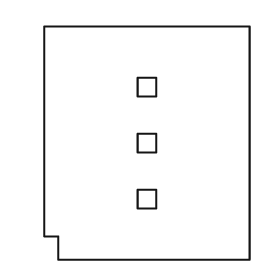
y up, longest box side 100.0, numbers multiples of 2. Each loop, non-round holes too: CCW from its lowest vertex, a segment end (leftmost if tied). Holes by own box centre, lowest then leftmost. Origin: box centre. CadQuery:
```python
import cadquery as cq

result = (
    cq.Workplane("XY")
    .moveTo(-38.0, -50.0)
    .lineTo(44.0, -50.0)
    .lineTo(44.0, 50.0)
    .lineTo(-44.0, 50.0)
    .lineTo(-44.0, -40.0)
    .lineTo(-38.0, -40.0)
    .close()
    .moveTo(-4.0, -28.0)
    .lineTo(4.0, -28.0)
    .lineTo(4.0, -20.0)
    .lineTo(-4.0, -20.0)
    .close()
    .moveTo(-4.0, -4.0)
    .lineTo(4.0, -4.0)
    .lineTo(4.0, 4.0)
    .lineTo(-4.0, 4.0)
    .close()
    .moveTo(-4.0, 20.0)
    .lineTo(4.0, 20.0)
    .lineTo(4.0, 28.0)
    .lineTo(-4.0, 28.0)
    .close()
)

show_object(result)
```